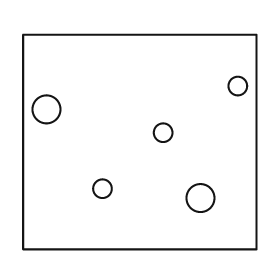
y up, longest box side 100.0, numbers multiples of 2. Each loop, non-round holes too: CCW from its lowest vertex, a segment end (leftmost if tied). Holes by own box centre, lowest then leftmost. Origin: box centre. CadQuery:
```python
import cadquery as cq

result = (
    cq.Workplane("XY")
    .moveTo(-50.0, -46.0)
    .lineTo(50.0, -46.0)
    .lineTo(50.0, 46.0)
    .lineTo(-50.0, 46.0)
    .close()
    .moveTo(26.0, -24.0)
    .circle(6.0)
    .moveTo(-16.0, -20.0)
    .circle(4.0)
    .moveTo(10.0, 4.0)
    .circle(4.0)
    .moveTo(-40.0, 14.0)
    .circle(6.0)
    .moveTo(42.0, 24.0)
    .circle(4.0)
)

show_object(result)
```